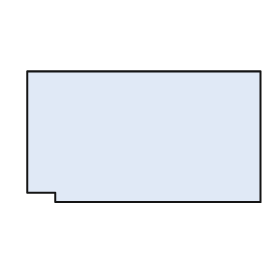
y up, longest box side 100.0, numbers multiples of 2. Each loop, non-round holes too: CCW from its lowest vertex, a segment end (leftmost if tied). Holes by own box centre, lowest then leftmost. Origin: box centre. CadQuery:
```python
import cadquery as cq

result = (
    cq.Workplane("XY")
    .moveTo(-38.0, -28.0)
    .lineTo(50.0, -28.0)
    .lineTo(50.0, 28.0)
    .lineTo(-50.0, 28.0)
    .lineTo(-50.0, -24.0)
    .lineTo(-38.0, -24.0)
    .close()
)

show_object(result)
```